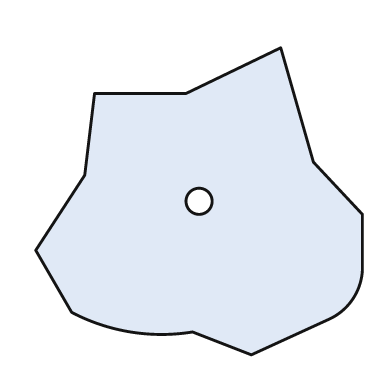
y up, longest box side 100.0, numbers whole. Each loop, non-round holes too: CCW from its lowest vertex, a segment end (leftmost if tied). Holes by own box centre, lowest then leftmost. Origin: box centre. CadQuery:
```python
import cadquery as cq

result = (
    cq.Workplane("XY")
    .moveTo(16.0, -47.0)
    .lineTo(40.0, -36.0)
    .threePointArc((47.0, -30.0), (50.0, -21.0))
    .lineTo(50.0, -4.0)
    .lineTo(35.0, 12.0)
    .lineTo(25.0, 47.0)
    .lineTo(-4.0, 33.0)
    .lineTo(-32.0, 33.0)
    .lineTo(-35.0, 8.0)
    .lineTo(-50.0, -15.0)
    .lineTo(-39.0, -34.0)
    .threePointArc((-21.0, -40.0), (-2.0, -40.0))
    .close()
    .moveTo(0.0, 0.0)
    .circle(4.0)
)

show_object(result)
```